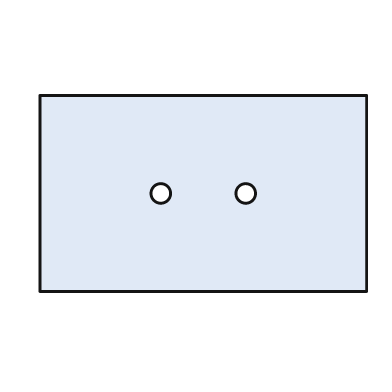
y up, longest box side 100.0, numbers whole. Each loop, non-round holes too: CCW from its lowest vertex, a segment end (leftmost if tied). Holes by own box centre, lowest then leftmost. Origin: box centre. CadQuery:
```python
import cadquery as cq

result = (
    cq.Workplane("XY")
    .moveTo(-50.0, -30.0)
    .lineTo(50.0, -30.0)
    .lineTo(50.0, 30.0)
    .lineTo(-50.0, 30.0)
    .close()
    .moveTo(-13.0, 0.0)
    .circle(3.0)
    .moveTo(13.0, 0.0)
    .circle(3.0)
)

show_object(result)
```